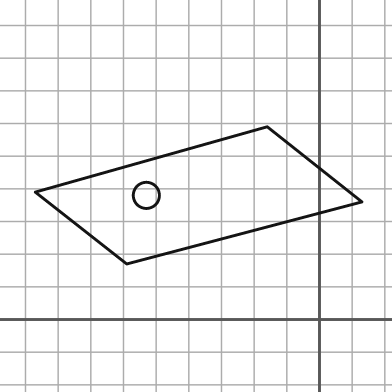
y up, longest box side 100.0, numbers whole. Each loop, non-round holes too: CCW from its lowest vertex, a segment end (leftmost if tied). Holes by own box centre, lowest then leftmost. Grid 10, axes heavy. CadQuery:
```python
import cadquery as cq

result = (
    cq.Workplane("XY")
    .moveTo(-59.0, 17.0)
    .lineTo(13.0, 36.0)
    .lineTo(-16.0, 59.0)
    .lineTo(-87.0, 39.0)
    .close()
    .moveTo(-53.0, 38.0)
    .circle(4.0)
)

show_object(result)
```